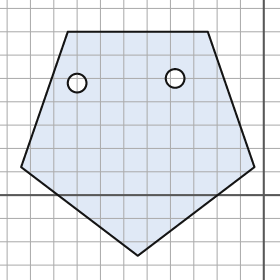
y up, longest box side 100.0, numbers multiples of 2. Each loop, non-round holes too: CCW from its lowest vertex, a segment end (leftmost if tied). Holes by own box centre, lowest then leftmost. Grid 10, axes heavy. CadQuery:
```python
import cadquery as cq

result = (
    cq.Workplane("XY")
    .moveTo(-54.0, -26.0)
    .lineTo(-4.0, 12.0)
    .lineTo(-24.0, 70.0)
    .lineTo(-84.0, 70.0)
    .lineTo(-104.0, 12.0)
    .close()
    .moveTo(-80.0, 48.0)
    .circle(4.0)
    .moveTo(-38.0, 50.0)
    .circle(4.0)
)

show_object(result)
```